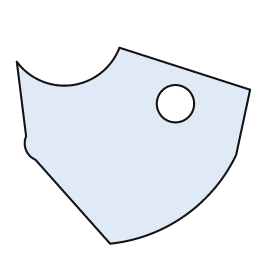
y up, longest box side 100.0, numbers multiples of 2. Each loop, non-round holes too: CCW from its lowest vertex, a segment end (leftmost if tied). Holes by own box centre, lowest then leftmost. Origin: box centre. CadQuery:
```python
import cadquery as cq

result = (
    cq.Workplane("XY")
    .moveTo(-10.0, -42.0)
    .threePointArc((22.0, -30.0), (44.0, -4.0))
    .lineTo(50.0, 24.0)
    .lineTo(-6.0, 42.0)
    .threePointArc((-26.0, 26.0), (-50.0, 36.0))
    .lineTo(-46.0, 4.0)
    .threePointArc((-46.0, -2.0), (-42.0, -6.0))
    .close()
    .moveTo(18.0, 18.0)
    .circle(8.0)
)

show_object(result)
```